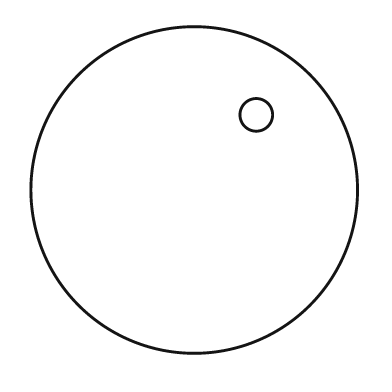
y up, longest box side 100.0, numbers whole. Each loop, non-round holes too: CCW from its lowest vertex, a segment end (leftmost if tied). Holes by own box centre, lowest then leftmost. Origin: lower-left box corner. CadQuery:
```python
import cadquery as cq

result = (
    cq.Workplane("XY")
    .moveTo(50.0, 50.0)
    .circle(50.0)
    .moveTo(69.0, 73.0)
    .circle(5.0)
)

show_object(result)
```